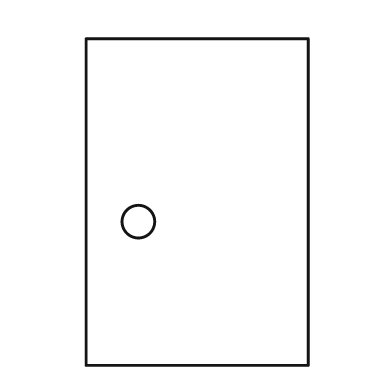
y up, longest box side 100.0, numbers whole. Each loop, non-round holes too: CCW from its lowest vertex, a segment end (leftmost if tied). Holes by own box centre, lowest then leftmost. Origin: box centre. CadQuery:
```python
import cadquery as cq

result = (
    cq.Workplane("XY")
    .moveTo(-34.0, -50.0)
    .lineTo(34.0, -50.0)
    .lineTo(34.0, 50.0)
    .lineTo(-34.0, 50.0)
    .close()
    .moveTo(-18.0, -6.0)
    .circle(5.0)
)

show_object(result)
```